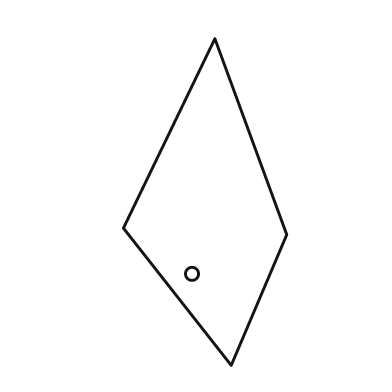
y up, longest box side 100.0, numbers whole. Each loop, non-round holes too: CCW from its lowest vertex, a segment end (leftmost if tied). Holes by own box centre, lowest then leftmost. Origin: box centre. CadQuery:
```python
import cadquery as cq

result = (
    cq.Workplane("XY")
    .moveTo(8.0, -50.0)
    .lineTo(25.0, -10.0)
    .lineTo(3.0, 50.0)
    .lineTo(-25.0, -8.0)
    .close()
    .moveTo(-4.0, -22.0)
    .circle(2.0)
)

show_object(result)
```